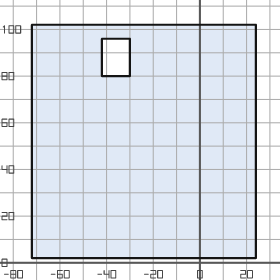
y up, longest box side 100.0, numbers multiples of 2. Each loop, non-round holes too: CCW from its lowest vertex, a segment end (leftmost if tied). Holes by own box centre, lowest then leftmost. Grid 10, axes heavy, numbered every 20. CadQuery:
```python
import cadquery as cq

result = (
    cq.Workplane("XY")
    .moveTo(-72.0, 2.0)
    .lineTo(24.0, 2.0)
    .lineTo(24.0, 102.0)
    .lineTo(-72.0, 102.0)
    .close()
    .moveTo(-42.0, 80.0)
    .lineTo(-30.0, 80.0)
    .lineTo(-30.0, 96.0)
    .lineTo(-42.0, 96.0)
    .close()
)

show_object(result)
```